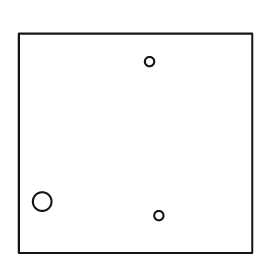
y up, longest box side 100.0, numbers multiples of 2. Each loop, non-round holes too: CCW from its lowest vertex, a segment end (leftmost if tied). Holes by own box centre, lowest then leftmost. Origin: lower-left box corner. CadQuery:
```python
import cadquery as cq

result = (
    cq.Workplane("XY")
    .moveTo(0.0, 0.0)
    .lineTo(100.0, 0.0)
    .lineTo(100.0, 94.0)
    .lineTo(0.0, 94.0)
    .close()
    .moveTo(60.0, 16.0)
    .circle(2.0)
    .moveTo(10.0, 22.0)
    .circle(4.0)
    .moveTo(56.0, 82.0)
    .circle(2.0)
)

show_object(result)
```